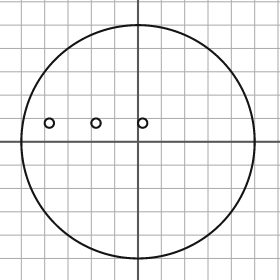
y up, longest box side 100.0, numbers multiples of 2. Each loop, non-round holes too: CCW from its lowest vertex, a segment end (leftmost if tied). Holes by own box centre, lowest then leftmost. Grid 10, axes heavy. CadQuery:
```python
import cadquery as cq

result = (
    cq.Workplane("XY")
    .moveTo(0.0, 0.0)
    .circle(50.0)
    .moveTo(-38.0, 8.0)
    .circle(2.0)
    .moveTo(-18.0, 8.0)
    .circle(2.0)
    .moveTo(2.0, 8.0)
    .circle(2.0)
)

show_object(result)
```